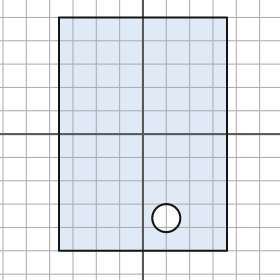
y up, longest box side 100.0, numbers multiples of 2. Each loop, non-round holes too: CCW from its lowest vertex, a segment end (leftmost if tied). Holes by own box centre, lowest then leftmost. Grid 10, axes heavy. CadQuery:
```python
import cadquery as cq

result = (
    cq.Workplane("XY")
    .moveTo(-36.0, -50.0)
    .lineTo(36.0, -50.0)
    .lineTo(36.0, 50.0)
    .lineTo(-36.0, 50.0)
    .close()
    .moveTo(10.0, -36.0)
    .circle(6.0)
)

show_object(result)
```